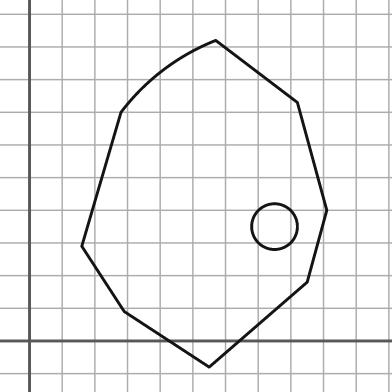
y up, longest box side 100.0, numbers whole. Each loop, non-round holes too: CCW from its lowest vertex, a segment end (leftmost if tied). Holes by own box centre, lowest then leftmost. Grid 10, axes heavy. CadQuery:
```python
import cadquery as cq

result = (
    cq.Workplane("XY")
    .moveTo(55.0, -8.0)
    .lineTo(85.0, 18.0)
    .lineTo(91.0, 40.0)
    .lineTo(82.0, 73.0)
    .lineTo(57.0, 92.0)
    .threePointArc((41.0, 83.0), (28.0, 70.0))
    .lineTo(16.0, 29.0)
    .lineTo(29.0, 9.0)
    .close()
    .moveTo(75.0, 35.0)
    .circle(7.0)
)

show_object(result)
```